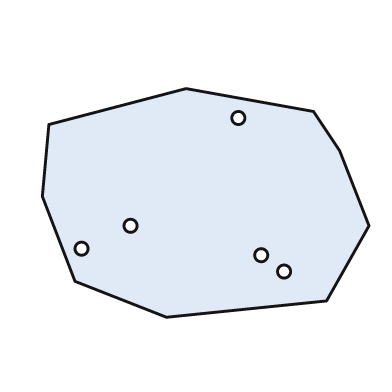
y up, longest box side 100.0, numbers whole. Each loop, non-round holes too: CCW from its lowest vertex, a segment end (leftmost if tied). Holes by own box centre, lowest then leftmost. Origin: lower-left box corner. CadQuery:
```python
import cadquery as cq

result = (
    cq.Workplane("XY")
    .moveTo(38.0, 0.0)
    .lineTo(87.0, 5.0)
    .lineTo(100.0, 28.0)
    .lineTo(91.0, 51.0)
    .lineTo(83.0, 63.0)
    .lineTo(44.0, 70.0)
    .lineTo(2.0, 59.0)
    .lineTo(0.0, 37.0)
    .lineTo(10.0, 11.0)
    .close()
    .moveTo(74.0, 14.0)
    .circle(2.0)
    .moveTo(67.0, 19.0)
    .circle(2.0)
    .moveTo(12.0, 21.0)
    .circle(2.0)
    .moveTo(27.0, 28.0)
    .circle(2.0)
    .moveTo(60.0, 61.0)
    .circle(2.0)
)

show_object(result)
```